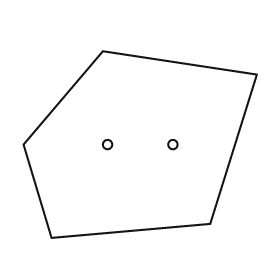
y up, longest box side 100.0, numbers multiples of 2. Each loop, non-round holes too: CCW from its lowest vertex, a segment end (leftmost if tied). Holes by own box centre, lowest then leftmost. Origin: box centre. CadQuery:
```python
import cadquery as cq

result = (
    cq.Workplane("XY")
    .moveTo(-38.0, -40.0)
    .lineTo(30.0, -34.0)
    .lineTo(50.0, 30.0)
    .lineTo(-16.0, 40.0)
    .lineTo(-50.0, 0.0)
    .close()
    .moveTo(-14.0, 0.0)
    .circle(2.0)
    .moveTo(14.0, 0.0)
    .circle(2.0)
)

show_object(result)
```